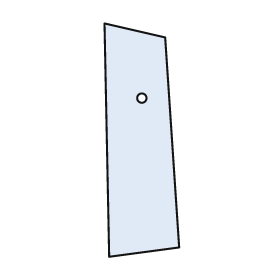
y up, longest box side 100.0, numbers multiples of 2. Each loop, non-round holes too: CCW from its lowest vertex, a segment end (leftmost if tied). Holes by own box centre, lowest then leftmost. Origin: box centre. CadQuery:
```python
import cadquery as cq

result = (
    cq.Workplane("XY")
    .moveTo(-14.0, -50.0)
    .lineTo(16.0, -46.0)
    .lineTo(10.0, 44.0)
    .lineTo(-16.0, 50.0)
    .close()
    .moveTo(0.0, 18.0)
    .circle(2.0)
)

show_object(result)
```